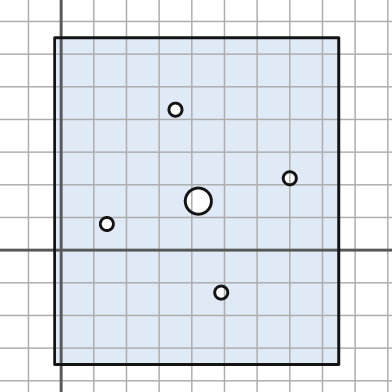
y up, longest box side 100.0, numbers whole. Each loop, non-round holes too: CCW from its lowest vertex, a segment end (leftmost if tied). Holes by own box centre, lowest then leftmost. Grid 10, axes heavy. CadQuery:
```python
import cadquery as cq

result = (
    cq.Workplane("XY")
    .moveTo(-2.0, -35.0)
    .lineTo(85.0, -35.0)
    .lineTo(85.0, 65.0)
    .lineTo(-2.0, 65.0)
    .close()
    .moveTo(49.0, -13.0)
    .circle(2.0)
    .moveTo(14.0, 8.0)
    .circle(2.0)
    .moveTo(42.0, 15.0)
    .circle(4.0)
    .moveTo(70.0, 22.0)
    .circle(2.0)
    .moveTo(35.0, 43.0)
    .circle(2.0)
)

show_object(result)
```